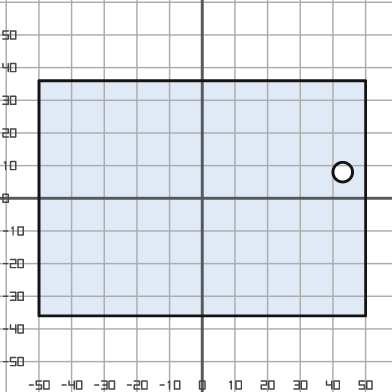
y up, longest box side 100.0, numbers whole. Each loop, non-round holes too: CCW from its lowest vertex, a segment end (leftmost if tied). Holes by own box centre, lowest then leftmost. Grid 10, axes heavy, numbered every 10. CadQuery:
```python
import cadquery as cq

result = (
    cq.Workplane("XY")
    .moveTo(-50.0, -36.0)
    .lineTo(50.0, -36.0)
    .lineTo(50.0, 36.0)
    .lineTo(-50.0, 36.0)
    .close()
    .moveTo(43.0, 8.0)
    .circle(3.0)
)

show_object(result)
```